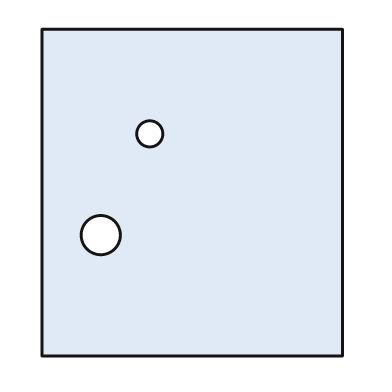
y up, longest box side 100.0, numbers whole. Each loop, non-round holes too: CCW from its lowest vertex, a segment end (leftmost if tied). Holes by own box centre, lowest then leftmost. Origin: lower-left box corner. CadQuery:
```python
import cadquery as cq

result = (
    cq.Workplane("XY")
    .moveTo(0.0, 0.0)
    .lineTo(92.0, 0.0)
    .lineTo(92.0, 100.0)
    .lineTo(0.0, 100.0)
    .close()
    .moveTo(18.0, 37.0)
    .circle(6.0)
    .moveTo(33.0, 68.0)
    .circle(4.0)
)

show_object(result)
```